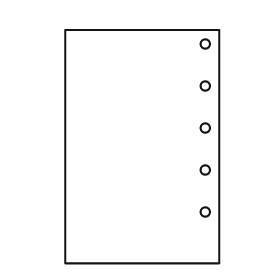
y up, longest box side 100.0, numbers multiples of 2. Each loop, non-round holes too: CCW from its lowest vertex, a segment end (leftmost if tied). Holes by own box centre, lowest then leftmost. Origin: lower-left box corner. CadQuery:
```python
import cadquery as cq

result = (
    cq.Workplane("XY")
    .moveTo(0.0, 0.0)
    .lineTo(66.0, 0.0)
    .lineTo(66.0, 100.0)
    .lineTo(0.0, 100.0)
    .close()
    .moveTo(60.0, 22.0)
    .circle(2.0)
    .moveTo(60.0, 40.0)
    .circle(2.0)
    .moveTo(60.0, 58.0)
    .circle(2.0)
    .moveTo(60.0, 76.0)
    .circle(2.0)
    .moveTo(60.0, 94.0)
    .circle(2.0)
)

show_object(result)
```